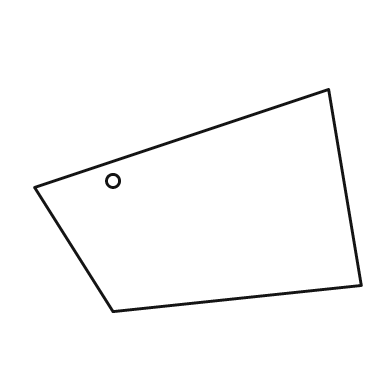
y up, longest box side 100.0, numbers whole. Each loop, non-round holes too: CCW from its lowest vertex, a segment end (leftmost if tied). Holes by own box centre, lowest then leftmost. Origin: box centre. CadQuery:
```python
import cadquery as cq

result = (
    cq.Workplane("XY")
    .moveTo(-26.0, -34.0)
    .lineTo(50.0, -26.0)
    .lineTo(40.0, 34.0)
    .lineTo(-50.0, 4.0)
    .close()
    .moveTo(-26.0, 6.0)
    .circle(2.0)
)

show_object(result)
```